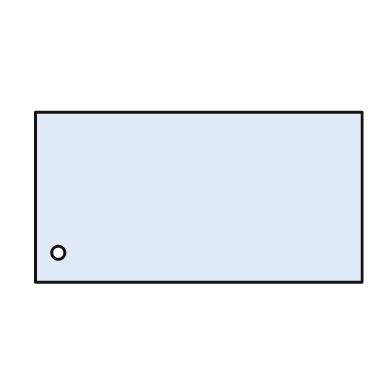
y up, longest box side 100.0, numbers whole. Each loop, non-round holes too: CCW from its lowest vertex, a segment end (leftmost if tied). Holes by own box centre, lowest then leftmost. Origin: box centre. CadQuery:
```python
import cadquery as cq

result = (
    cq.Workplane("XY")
    .moveTo(-50.0, -26.0)
    .lineTo(50.0, -26.0)
    .lineTo(50.0, 26.0)
    .lineTo(-50.0, 26.0)
    .close()
    .moveTo(-43.0, -17.0)
    .circle(2.0)
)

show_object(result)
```